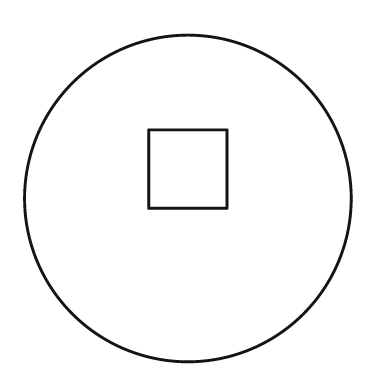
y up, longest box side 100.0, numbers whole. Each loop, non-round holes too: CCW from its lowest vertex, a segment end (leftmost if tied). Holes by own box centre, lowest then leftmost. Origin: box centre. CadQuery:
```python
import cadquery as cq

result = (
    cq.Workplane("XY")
    .moveTo(0.0, 0.0)
    .circle(50.0)
    .moveTo(-12.0, -3.0)
    .lineTo(12.0, -3.0)
    .lineTo(12.0, 21.0)
    .lineTo(-12.0, 21.0)
    .close()
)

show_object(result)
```